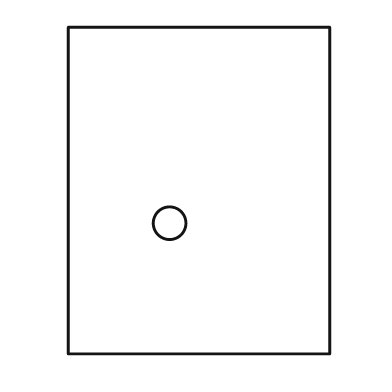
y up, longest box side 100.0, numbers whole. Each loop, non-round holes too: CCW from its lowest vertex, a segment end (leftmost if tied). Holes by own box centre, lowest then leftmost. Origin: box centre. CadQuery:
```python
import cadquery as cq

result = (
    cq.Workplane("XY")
    .moveTo(-40.0, -50.0)
    .lineTo(40.0, -50.0)
    .lineTo(40.0, 50.0)
    .lineTo(-40.0, 50.0)
    .close()
    .moveTo(-9.0, -10.0)
    .circle(5.0)
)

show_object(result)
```